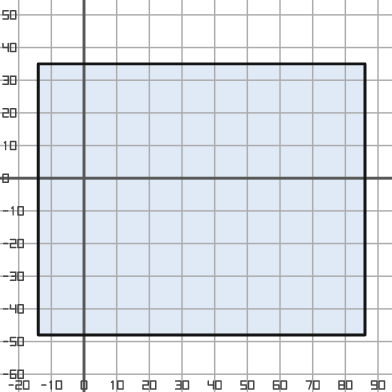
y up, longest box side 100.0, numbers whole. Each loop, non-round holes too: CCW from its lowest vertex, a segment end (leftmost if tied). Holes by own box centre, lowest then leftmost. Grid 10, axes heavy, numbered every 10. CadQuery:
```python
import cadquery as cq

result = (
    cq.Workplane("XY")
    .moveTo(-14.0, -48.0)
    .lineTo(86.0, -48.0)
    .lineTo(86.0, 35.0)
    .lineTo(-14.0, 35.0)
    .close()
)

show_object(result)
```